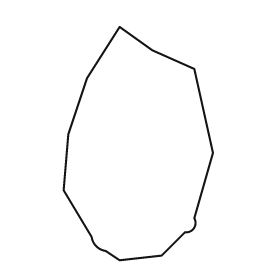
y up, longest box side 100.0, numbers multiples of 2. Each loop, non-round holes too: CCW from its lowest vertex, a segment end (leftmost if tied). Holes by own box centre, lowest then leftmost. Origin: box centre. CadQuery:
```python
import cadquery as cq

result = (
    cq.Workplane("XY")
    .moveTo(-8.0, -50.0)
    .lineTo(10.0, -48.0)
    .lineTo(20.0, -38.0)
    .threePointArc((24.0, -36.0), (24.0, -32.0))
    .lineTo(32.0, -4.0)
    .lineTo(24.0, 32.0)
    .lineTo(6.0, 40.0)
    .lineTo(-8.0, 50.0)
    .lineTo(-22.0, 28.0)
    .lineTo(-30.0, 4.0)
    .lineTo(-32.0, -20.0)
    .lineTo(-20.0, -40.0)
    .threePointArc((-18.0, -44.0), (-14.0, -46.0))
    .close()
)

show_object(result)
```